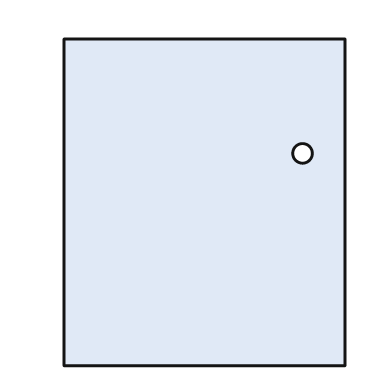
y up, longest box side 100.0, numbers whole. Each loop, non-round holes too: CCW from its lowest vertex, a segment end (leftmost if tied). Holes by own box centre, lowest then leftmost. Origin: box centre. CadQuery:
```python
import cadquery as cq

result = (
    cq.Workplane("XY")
    .moveTo(-43.0, -50.0)
    .lineTo(43.0, -50.0)
    .lineTo(43.0, 50.0)
    .lineTo(-43.0, 50.0)
    .close()
    .moveTo(30.0, 15.0)
    .circle(3.0)
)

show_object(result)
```